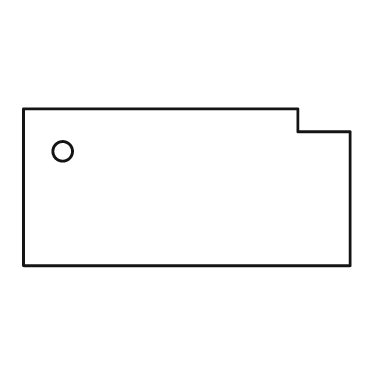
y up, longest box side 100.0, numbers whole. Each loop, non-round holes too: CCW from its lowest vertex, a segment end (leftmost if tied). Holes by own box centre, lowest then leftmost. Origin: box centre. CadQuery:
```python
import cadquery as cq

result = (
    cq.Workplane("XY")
    .moveTo(-50.0, -24.0)
    .lineTo(50.0, -24.0)
    .lineTo(50.0, 17.0)
    .lineTo(34.0, 17.0)
    .lineTo(34.0, 24.0)
    .lineTo(-50.0, 24.0)
    .close()
    .moveTo(-38.0, 11.0)
    .circle(3.0)
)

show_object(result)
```